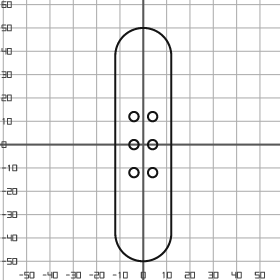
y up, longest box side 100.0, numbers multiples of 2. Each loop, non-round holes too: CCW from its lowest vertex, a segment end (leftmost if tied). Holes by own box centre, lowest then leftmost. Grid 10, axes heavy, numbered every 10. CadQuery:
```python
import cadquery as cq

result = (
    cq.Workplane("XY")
    .moveTo(-12.0, -38.0)
    .threePointArc((0.0, -50.0), (12.0, -38.0))
    .lineTo(12.0, 38.0)
    .threePointArc((0.0, 50.0), (-12.0, 38.0))
    .close()
    .moveTo(-4.0, -12.0)
    .circle(2.0)
    .moveTo(4.0, -12.0)
    .circle(2.0)
    .moveTo(-4.0, 0.0)
    .circle(2.0)
    .moveTo(4.0, 0.0)
    .circle(2.0)
    .moveTo(-4.0, 12.0)
    .circle(2.0)
    .moveTo(4.0, 12.0)
    .circle(2.0)
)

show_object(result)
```